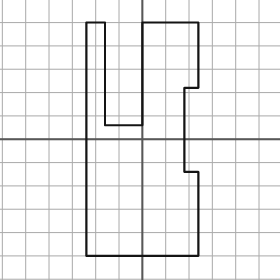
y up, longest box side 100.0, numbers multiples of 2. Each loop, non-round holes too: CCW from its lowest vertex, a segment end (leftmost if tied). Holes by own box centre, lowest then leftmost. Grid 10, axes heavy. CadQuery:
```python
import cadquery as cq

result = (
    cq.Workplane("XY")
    .moveTo(-24.0, -50.0)
    .lineTo(24.0, -50.0)
    .lineTo(24.0, -14.0)
    .lineTo(18.0, -14.0)
    .lineTo(18.0, 22.0)
    .lineTo(24.0, 22.0)
    .lineTo(24.0, 50.0)
    .lineTo(0.0, 50.0)
    .lineTo(0.0, 6.0)
    .lineTo(-16.0, 6.0)
    .lineTo(-16.0, 50.0)
    .lineTo(-24.0, 50.0)
    .close()
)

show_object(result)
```